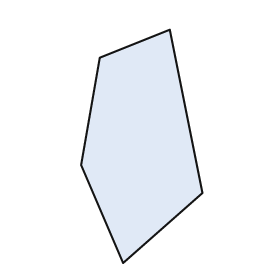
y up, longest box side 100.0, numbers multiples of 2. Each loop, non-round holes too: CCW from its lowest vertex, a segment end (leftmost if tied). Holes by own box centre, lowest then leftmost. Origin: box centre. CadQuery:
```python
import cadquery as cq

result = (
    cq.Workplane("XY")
    .moveTo(-8.0, -50.0)
    .lineTo(26.0, -20.0)
    .lineTo(12.0, 50.0)
    .lineTo(-18.0, 38.0)
    .lineTo(-26.0, -8.0)
    .close()
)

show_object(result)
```